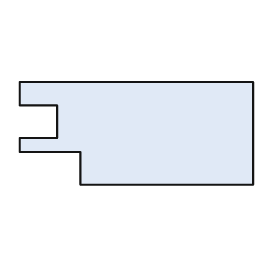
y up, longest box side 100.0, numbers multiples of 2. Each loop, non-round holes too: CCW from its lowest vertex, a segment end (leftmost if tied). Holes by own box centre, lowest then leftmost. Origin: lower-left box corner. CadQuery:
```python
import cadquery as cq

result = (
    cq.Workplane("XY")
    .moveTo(26.0, 0.0)
    .lineTo(100.0, 0.0)
    .lineTo(100.0, 44.0)
    .lineTo(0.0, 44.0)
    .lineTo(0.0, 34.0)
    .lineTo(16.0, 34.0)
    .lineTo(16.0, 20.0)
    .lineTo(0.0, 20.0)
    .lineTo(0.0, 14.0)
    .lineTo(26.0, 14.0)
    .close()
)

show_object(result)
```